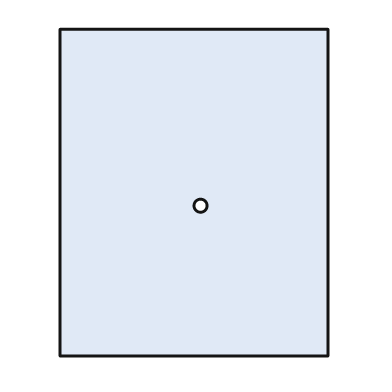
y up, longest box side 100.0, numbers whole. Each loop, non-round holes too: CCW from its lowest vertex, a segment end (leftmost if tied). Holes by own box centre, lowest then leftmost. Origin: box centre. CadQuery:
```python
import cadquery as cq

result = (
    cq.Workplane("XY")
    .moveTo(-41.0, -50.0)
    .lineTo(41.0, -50.0)
    .lineTo(41.0, 50.0)
    .lineTo(-41.0, 50.0)
    .close()
    .moveTo(2.0, -4.0)
    .circle(2.0)
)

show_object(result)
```